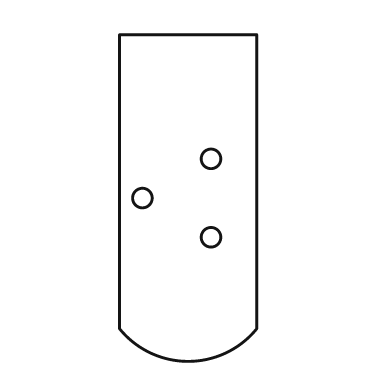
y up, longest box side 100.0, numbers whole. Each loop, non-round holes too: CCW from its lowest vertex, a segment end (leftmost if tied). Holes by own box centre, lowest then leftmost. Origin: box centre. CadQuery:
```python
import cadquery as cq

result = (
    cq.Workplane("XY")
    .moveTo(-21.0, -40.0)
    .threePointArc((0.0, -50.0), (21.0, -40.0))
    .lineTo(21.0, 50.0)
    .lineTo(-21.0, 50.0)
    .close()
    .moveTo(7.0, -12.0)
    .circle(3.0)
    .moveTo(-14.0, 0.0)
    .circle(3.0)
    .moveTo(7.0, 12.0)
    .circle(3.0)
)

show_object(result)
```